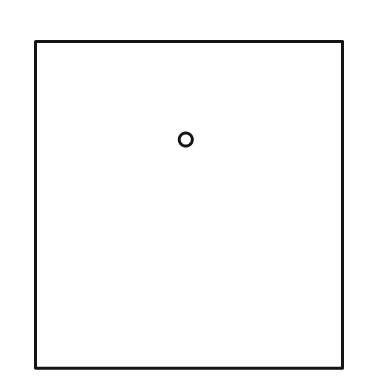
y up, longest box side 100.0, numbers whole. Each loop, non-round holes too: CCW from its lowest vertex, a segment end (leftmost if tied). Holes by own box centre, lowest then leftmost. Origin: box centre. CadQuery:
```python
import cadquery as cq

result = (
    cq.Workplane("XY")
    .moveTo(-47.0, -50.0)
    .lineTo(47.0, -50.0)
    .lineTo(47.0, 50.0)
    .lineTo(-47.0, 50.0)
    .close()
    .moveTo(-1.0, 20.0)
    .circle(2.0)
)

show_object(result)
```